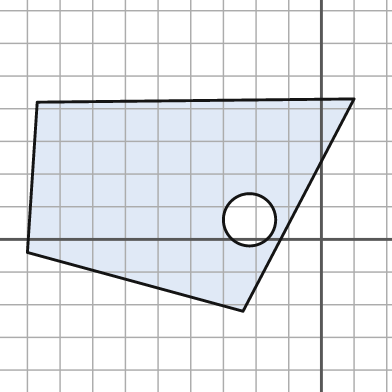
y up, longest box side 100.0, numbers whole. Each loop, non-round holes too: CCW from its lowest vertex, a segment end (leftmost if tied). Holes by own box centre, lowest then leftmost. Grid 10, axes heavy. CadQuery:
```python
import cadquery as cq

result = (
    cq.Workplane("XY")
    .moveTo(-24.0, -22.0)
    .lineTo(10.0, 43.0)
    .lineTo(-87.0, 42.0)
    .lineTo(-90.0, -4.0)
    .close()
    .moveTo(-22.0, 6.0)
    .circle(8.0)
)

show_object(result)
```